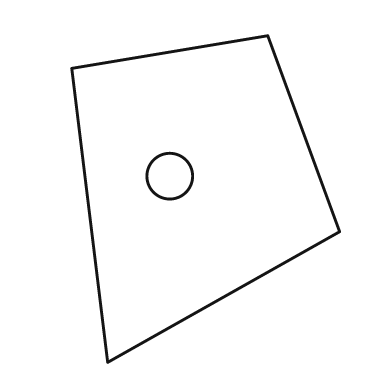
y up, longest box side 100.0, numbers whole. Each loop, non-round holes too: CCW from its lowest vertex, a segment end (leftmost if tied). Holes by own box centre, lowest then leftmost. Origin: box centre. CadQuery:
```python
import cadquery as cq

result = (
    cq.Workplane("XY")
    .moveTo(-30.0, -50.0)
    .lineTo(41.0, -10.0)
    .lineTo(19.0, 50.0)
    .lineTo(-41.0, 40.0)
    .close()
    .moveTo(-11.0, 7.0)
    .circle(7.0)
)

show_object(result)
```